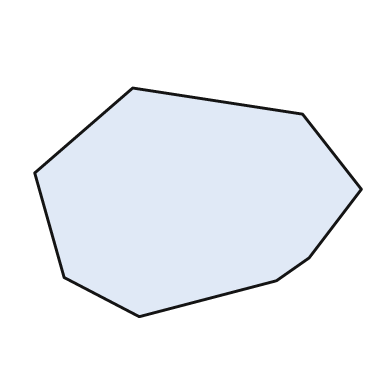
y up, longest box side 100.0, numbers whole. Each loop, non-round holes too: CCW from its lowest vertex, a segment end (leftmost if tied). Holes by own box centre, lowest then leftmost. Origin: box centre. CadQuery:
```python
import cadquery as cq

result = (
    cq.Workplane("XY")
    .moveTo(-18.0, -35.0)
    .lineTo(24.0, -24.0)
    .lineTo(34.0, -17.0)
    .lineTo(50.0, 4.0)
    .lineTo(32.0, 27.0)
    .lineTo(-20.0, 35.0)
    .lineTo(-50.0, 9.0)
    .lineTo(-41.0, -23.0)
    .close()
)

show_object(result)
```